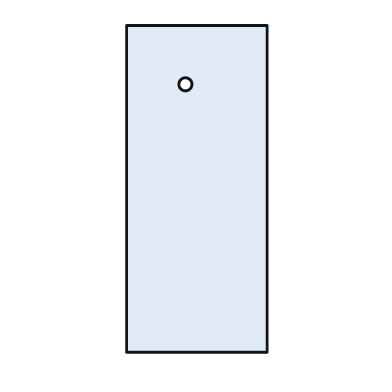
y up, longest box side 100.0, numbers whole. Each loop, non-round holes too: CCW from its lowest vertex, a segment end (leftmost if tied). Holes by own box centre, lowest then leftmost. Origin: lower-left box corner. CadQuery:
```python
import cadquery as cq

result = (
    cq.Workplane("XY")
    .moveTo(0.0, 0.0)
    .lineTo(43.0, 0.0)
    .lineTo(43.0, 100.0)
    .lineTo(0.0, 100.0)
    .close()
    .moveTo(18.0, 82.0)
    .circle(2.0)
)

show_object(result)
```